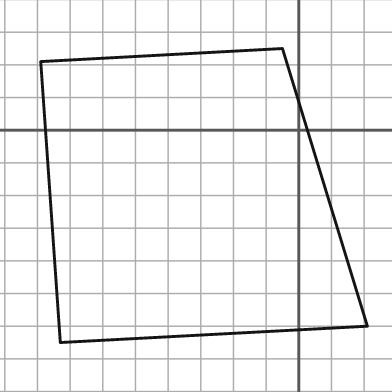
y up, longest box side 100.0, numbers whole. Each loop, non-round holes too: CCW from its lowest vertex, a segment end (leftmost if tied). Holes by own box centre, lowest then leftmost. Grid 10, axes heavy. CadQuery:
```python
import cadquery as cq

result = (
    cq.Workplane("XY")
    .moveTo(-73.0, -65.0)
    .lineTo(21.0, -60.0)
    .lineTo(-5.0, 25.0)
    .lineTo(-79.0, 21.0)
    .close()
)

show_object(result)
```